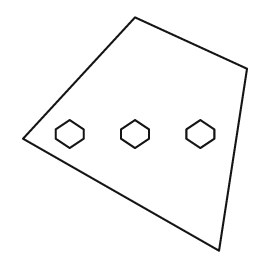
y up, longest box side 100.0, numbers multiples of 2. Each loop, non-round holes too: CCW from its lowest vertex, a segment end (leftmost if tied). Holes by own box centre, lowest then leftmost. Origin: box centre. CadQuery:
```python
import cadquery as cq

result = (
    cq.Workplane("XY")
    .moveTo(36.0, -50.0)
    .lineTo(48.0, 28.0)
    .lineTo(0.0, 50.0)
    .lineTo(-48.0, -2.0)
    .close()
    .moveTo(-28.0, -6.0)
    .lineTo(-22.0, -2.0)
    .lineTo(-22.0, 2.0)
    .lineTo(-28.0, 6.0)
    .lineTo(-34.0, 2.0)
    .lineTo(-34.0, -2.0)
    .close()
    .moveTo(0.0, -6.0)
    .lineTo(6.0, -2.0)
    .lineTo(6.0, 2.0)
    .lineTo(0.0, 6.0)
    .lineTo(-6.0, 2.0)
    .lineTo(-6.0, -2.0)
    .close()
    .moveTo(28.0, -6.0)
    .lineTo(34.0, -2.0)
    .lineTo(34.0, 2.0)
    .lineTo(28.0, 6.0)
    .lineTo(22.0, 2.0)
    .lineTo(22.0, -2.0)
    .close()
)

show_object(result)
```